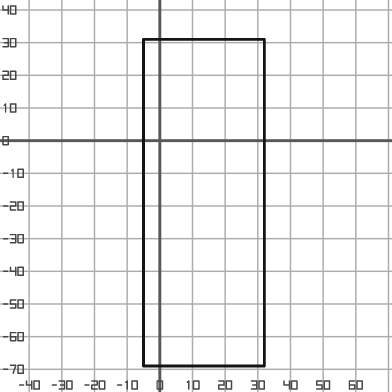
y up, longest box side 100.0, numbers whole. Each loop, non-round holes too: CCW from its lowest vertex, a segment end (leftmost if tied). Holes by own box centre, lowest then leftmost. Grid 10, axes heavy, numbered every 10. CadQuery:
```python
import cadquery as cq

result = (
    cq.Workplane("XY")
    .moveTo(-5.0, -69.0)
    .lineTo(32.0, -69.0)
    .lineTo(32.0, 31.0)
    .lineTo(-5.0, 31.0)
    .close()
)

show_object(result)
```